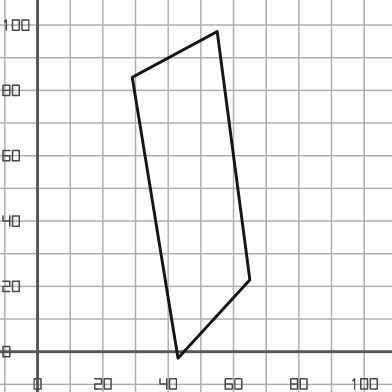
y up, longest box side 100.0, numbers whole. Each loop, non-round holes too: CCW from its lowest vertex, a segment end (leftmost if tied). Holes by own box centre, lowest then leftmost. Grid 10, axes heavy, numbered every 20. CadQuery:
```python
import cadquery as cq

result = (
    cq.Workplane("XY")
    .moveTo(43.0, -2.0)
    .lineTo(65.0, 22.0)
    .lineTo(55.0, 98.0)
    .lineTo(29.0, 84.0)
    .close()
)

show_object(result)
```